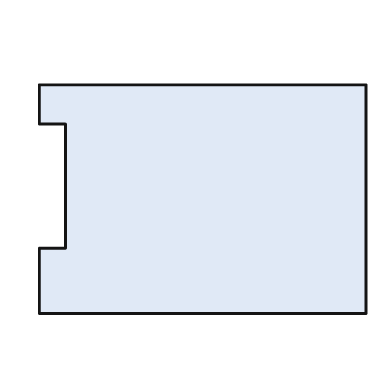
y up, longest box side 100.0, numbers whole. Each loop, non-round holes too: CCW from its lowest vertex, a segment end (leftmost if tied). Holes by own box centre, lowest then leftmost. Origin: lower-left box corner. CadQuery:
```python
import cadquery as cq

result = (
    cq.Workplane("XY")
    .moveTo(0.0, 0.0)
    .lineTo(100.0, 0.0)
    .lineTo(100.0, 70.0)
    .lineTo(0.0, 70.0)
    .lineTo(0.0, 58.0)
    .lineTo(8.0, 58.0)
    .lineTo(8.0, 20.0)
    .lineTo(0.0, 20.0)
    .close()
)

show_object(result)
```